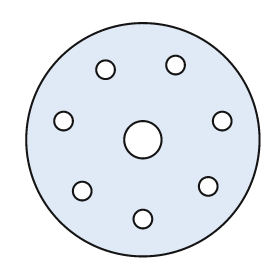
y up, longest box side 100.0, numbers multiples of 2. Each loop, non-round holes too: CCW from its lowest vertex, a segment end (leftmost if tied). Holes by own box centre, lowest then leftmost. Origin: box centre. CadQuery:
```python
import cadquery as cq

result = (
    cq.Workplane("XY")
    .moveTo(0.0, 0.0)
    .circle(50.0)
    .moveTo(0.0, -34.0)
    .circle(4.0)
    .moveTo(-26.0, -22.0)
    .circle(4.0)
    .moveTo(28.0, -20.0)
    .circle(4.0)
    .moveTo(0.0, 0.0)
    .circle(8.0)
    .moveTo(-34.0, 8.0)
    .circle(4.0)
    .moveTo(34.0, 8.0)
    .circle(4.0)
    .moveTo(-16.0, 30.0)
    .circle(4.0)
    .moveTo(14.0, 32.0)
    .circle(4.0)
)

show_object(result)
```